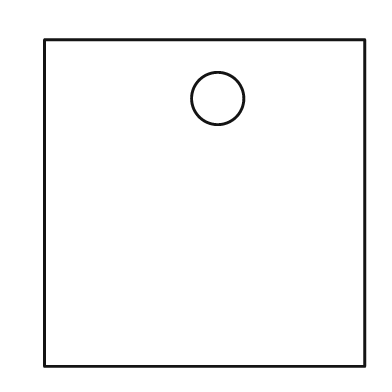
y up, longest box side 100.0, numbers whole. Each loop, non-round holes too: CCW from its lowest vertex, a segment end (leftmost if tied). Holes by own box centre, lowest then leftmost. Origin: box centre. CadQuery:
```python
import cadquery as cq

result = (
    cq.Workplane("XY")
    .moveTo(-49.0, -50.0)
    .lineTo(49.0, -50.0)
    .lineTo(49.0, 50.0)
    .lineTo(-49.0, 50.0)
    .close()
    .moveTo(4.0, 32.0)
    .circle(8.0)
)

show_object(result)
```